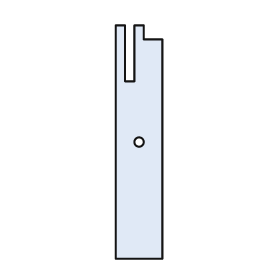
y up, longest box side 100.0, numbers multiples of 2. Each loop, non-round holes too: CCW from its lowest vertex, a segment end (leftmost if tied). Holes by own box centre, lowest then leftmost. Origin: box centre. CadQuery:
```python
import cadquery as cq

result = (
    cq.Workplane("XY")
    .moveTo(-10.0, -50.0)
    .lineTo(10.0, -50.0)
    .lineTo(10.0, 44.0)
    .lineTo(2.0, 44.0)
    .lineTo(2.0, 50.0)
    .lineTo(-2.0, 50.0)
    .lineTo(-2.0, 26.0)
    .lineTo(-6.0, 26.0)
    .lineTo(-6.0, 50.0)
    .lineTo(-10.0, 50.0)
    .close()
    .moveTo(0.0, 0.0)
    .circle(2.0)
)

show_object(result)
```